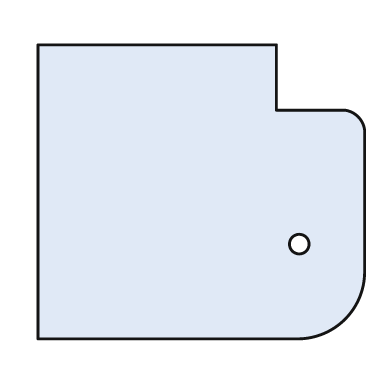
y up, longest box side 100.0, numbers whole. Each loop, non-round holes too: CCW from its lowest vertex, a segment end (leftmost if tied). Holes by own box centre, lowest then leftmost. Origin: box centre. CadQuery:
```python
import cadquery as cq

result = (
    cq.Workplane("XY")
    .moveTo(-50.0, -45.0)
    .lineTo(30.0, -45.0)
    .threePointArc((44.0, -39.0), (50.0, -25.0))
    .lineTo(50.0, 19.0)
    .threePointArc((48.0, 23.0), (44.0, 25.0))
    .lineTo(23.0, 25.0)
    .lineTo(23.0, 45.0)
    .lineTo(-50.0, 45.0)
    .close()
    .moveTo(30.0, -16.0)
    .circle(3.0)
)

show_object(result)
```